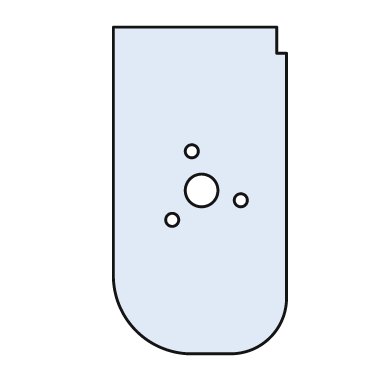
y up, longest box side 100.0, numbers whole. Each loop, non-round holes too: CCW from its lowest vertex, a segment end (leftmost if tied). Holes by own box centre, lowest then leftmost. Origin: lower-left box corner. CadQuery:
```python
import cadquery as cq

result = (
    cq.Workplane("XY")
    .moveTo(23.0, 0.0)
    .lineTo(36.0, 0.0)
    .threePointArc((48.0, 5.0), (53.0, 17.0))
    .lineTo(53.0, 92.0)
    .lineTo(50.0, 92.0)
    .lineTo(50.0, 100.0)
    .lineTo(0.0, 100.0)
    .lineTo(0.0, 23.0)
    .threePointArc((7.0, 7.0), (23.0, 0.0))
    .close()
    .moveTo(18.0, 41.0)
    .circle(2.0)
    .moveTo(39.0, 47.0)
    .circle(2.0)
    .moveTo(27.0, 50.0)
    .circle(5.0)
    .moveTo(24.0, 62.0)
    .circle(2.0)
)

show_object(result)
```